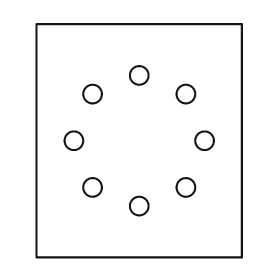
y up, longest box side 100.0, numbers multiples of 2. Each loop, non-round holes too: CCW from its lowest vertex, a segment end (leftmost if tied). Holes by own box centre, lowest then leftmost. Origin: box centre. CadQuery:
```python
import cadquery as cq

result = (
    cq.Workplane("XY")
    .moveTo(-44.0, -50.0)
    .lineTo(44.0, -50.0)
    .lineTo(44.0, 50.0)
    .lineTo(-44.0, 50.0)
    .close()
    .moveTo(0.0, -28.0)
    .circle(4.0)
    .moveTo(-20.0, -20.0)
    .circle(4.0)
    .moveTo(20.0, -20.0)
    .circle(4.0)
    .moveTo(-28.0, 0.0)
    .circle(4.0)
    .moveTo(28.0, 0.0)
    .circle(4.0)
    .moveTo(-20.0, 20.0)
    .circle(4.0)
    .moveTo(20.0, 20.0)
    .circle(4.0)
    .moveTo(0.0, 28.0)
    .circle(4.0)
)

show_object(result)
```